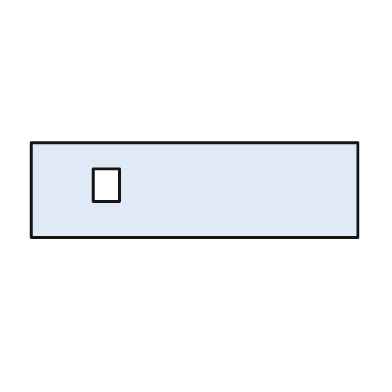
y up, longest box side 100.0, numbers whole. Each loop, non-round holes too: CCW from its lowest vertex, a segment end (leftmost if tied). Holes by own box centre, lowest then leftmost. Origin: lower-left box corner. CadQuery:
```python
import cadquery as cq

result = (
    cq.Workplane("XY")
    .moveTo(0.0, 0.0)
    .lineTo(100.0, 0.0)
    .lineTo(100.0, 29.0)
    .lineTo(0.0, 29.0)
    .close()
    .moveTo(19.0, 11.0)
    .lineTo(27.0, 11.0)
    .lineTo(27.0, 21.0)
    .lineTo(19.0, 21.0)
    .close()
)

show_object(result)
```